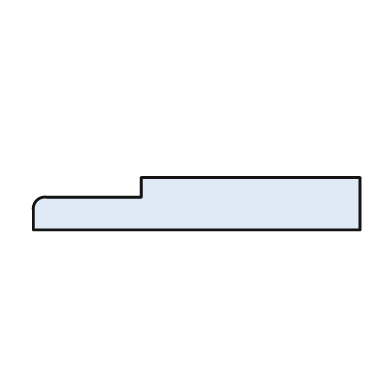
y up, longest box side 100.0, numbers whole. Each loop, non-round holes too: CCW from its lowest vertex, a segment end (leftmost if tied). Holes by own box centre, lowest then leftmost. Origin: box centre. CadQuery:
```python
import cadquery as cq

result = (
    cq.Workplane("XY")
    .moveTo(-50.0, -8.0)
    .lineTo(50.0, -8.0)
    .lineTo(50.0, 8.0)
    .lineTo(-17.0, 8.0)
    .lineTo(-17.0, 2.0)
    .lineTo(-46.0, 2.0)
    .threePointArc((-49.0, 1.0), (-50.0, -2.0))
    .close()
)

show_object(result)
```